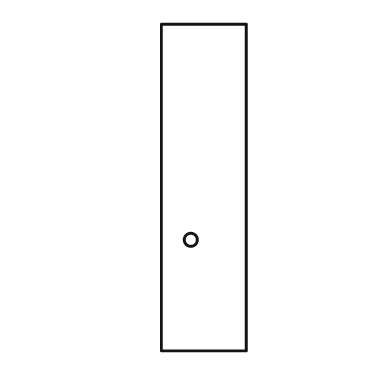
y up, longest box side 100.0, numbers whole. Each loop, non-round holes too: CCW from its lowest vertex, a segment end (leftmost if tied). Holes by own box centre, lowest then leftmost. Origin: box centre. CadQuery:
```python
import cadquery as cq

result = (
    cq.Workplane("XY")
    .moveTo(-13.0, -50.0)
    .lineTo(13.0, -50.0)
    .lineTo(13.0, 50.0)
    .lineTo(-13.0, 50.0)
    .close()
    .moveTo(-4.0, -16.0)
    .circle(2.0)
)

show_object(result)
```